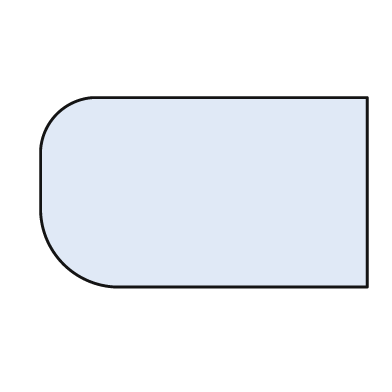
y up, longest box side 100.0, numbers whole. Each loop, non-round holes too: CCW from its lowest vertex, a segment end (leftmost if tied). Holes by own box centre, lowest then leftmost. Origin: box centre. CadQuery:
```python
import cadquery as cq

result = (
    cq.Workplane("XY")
    .moveTo(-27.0, -29.0)
    .lineTo(50.0, -29.0)
    .lineTo(50.0, 29.0)
    .lineTo(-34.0, 29.0)
    .threePointArc((-45.0, 24.0), (-50.0, 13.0))
    .lineTo(-50.0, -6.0)
    .threePointArc((-43.0, -22.0), (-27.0, -29.0))
    .close()
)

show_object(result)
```